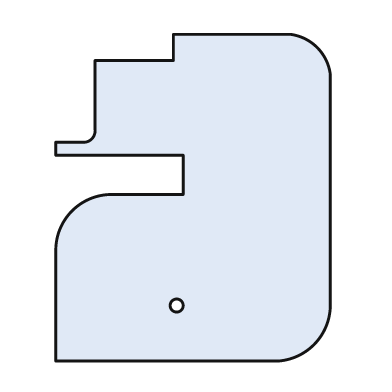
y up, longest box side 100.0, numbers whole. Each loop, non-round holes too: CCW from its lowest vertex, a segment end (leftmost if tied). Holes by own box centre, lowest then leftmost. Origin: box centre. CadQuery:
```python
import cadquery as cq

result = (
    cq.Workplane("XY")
    .moveTo(-42.0, -50.0)
    .lineTo(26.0, -50.0)
    .threePointArc((37.0, -45.0), (42.0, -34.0))
    .lineTo(42.0, 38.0)
    .threePointArc((38.0, 46.0), (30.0, 50.0))
    .lineTo(-6.0, 50.0)
    .lineTo(-6.0, 42.0)
    .lineTo(-30.0, 42.0)
    .lineTo(-30.0, 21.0)
    .threePointArc((-31.0, 18.0), (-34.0, 17.0))
    .lineTo(-42.0, 17.0)
    .lineTo(-42.0, 13.0)
    .lineTo(-3.0, 13.0)
    .lineTo(-3.0, 1.0)
    .lineTo(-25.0, 1.0)
    .threePointArc((-37.0, -4.0), (-42.0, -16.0))
    .close()
    .moveTo(-5.0, -33.0)
    .circle(2.0)
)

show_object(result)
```